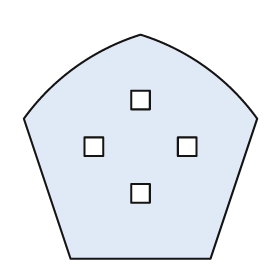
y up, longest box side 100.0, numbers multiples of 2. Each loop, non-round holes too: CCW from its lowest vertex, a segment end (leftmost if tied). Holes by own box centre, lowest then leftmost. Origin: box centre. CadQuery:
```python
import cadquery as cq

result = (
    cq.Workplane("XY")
    .moveTo(-30.0, -48.0)
    .lineTo(30.0, -48.0)
    .lineTo(50.0, 12.0)
    .threePointArc((28.0, 34.0), (0.0, 48.0))
    .threePointArc((-28.0, 34.0), (-50.0, 12.0))
    .close()
    .moveTo(-4.0, -24.0)
    .lineTo(4.0, -24.0)
    .lineTo(4.0, -16.0)
    .lineTo(-4.0, -16.0)
    .close()
    .moveTo(-24.0, -4.0)
    .lineTo(-16.0, -4.0)
    .lineTo(-16.0, 4.0)
    .lineTo(-24.0, 4.0)
    .close()
    .moveTo(16.0, -4.0)
    .lineTo(24.0, -4.0)
    .lineTo(24.0, 4.0)
    .lineTo(16.0, 4.0)
    .close()
    .moveTo(-4.0, 16.0)
    .lineTo(4.0, 16.0)
    .lineTo(4.0, 24.0)
    .lineTo(-4.0, 24.0)
    .close()
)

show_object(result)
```